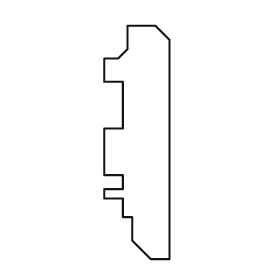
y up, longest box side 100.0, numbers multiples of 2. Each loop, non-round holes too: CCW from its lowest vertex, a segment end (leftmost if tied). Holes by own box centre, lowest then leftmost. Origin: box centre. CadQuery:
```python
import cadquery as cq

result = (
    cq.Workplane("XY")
    .moveTo(6.0, -50.0)
    .lineTo(14.0, -50.0)
    .lineTo(14.0, 44.0)
    .lineTo(8.0, 50.0)
    .lineTo(-4.0, 50.0)
    .lineTo(-4.0, 40.0)
    .lineTo(-8.0, 36.0)
    .lineTo(-14.0, 36.0)
    .lineTo(-14.0, 26.0)
    .lineTo(-6.0, 26.0)
    .lineTo(-6.0, 6.0)
    .lineTo(-14.0, 6.0)
    .lineTo(-14.0, -14.0)
    .lineTo(-6.0, -14.0)
    .lineTo(-6.0, -20.0)
    .lineTo(-14.0, -20.0)
    .lineTo(-14.0, -24.0)
    .lineTo(-6.0, -24.0)
    .lineTo(-6.0, -32.0)
    .lineTo(-2.0, -32.0)
    .lineTo(-2.0, -42.0)
    .close()
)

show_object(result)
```